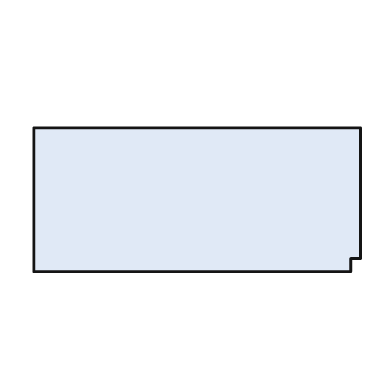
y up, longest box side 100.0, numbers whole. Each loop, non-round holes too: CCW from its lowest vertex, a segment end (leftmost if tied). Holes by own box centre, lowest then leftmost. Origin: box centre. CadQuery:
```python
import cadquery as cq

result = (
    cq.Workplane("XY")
    .moveTo(-50.0, -22.0)
    .lineTo(47.0, -22.0)
    .lineTo(47.0, -18.0)
    .lineTo(50.0, -18.0)
    .lineTo(50.0, 22.0)
    .lineTo(-50.0, 22.0)
    .close()
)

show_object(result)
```